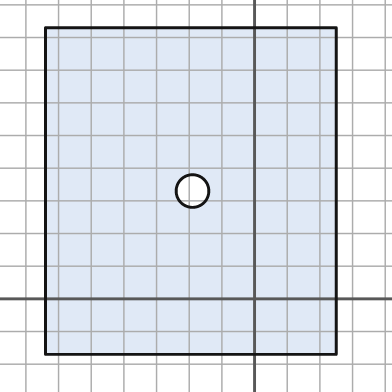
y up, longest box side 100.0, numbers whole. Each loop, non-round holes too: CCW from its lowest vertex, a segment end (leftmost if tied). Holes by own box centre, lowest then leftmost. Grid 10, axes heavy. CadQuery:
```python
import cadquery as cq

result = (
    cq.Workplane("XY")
    .moveTo(-64.0, -17.0)
    .lineTo(25.0, -17.0)
    .lineTo(25.0, 83.0)
    .lineTo(-64.0, 83.0)
    .close()
    .moveTo(-19.0, 33.0)
    .circle(5.0)
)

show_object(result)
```